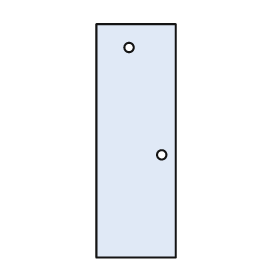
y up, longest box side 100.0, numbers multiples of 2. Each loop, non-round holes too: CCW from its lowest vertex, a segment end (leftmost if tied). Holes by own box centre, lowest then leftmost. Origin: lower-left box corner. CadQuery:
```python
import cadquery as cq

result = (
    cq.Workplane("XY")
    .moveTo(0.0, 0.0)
    .lineTo(34.0, 0.0)
    .lineTo(34.0, 100.0)
    .lineTo(0.0, 100.0)
    .close()
    .moveTo(28.0, 44.0)
    .circle(2.0)
    .moveTo(14.0, 90.0)
    .circle(2.0)
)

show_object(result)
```